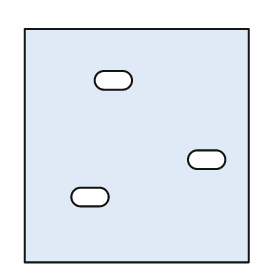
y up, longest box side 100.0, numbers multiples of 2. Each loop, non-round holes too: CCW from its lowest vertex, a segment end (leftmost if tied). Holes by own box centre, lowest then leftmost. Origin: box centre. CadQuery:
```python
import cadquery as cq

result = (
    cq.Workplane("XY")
    .moveTo(-48.0, -50.0)
    .lineTo(48.0, -50.0)
    .lineTo(48.0, 50.0)
    .lineTo(-48.0, 50.0)
    .close()
    .moveTo(-24.0, -26.0)
    .lineTo(-16.0, -26.0)
    .threePointArc((-12.0, -22.0), (-16.0, -18.0))
    .lineTo(-24.0, -18.0)
    .threePointArc((-28.0, -22.0), (-24.0, -26.0))
    .close()
    .moveTo(26.0, -10.0)
    .lineTo(34.0, -10.0)
    .threePointArc((38.0, -6.0), (34.0, -2.0))
    .lineTo(26.0, -2.0)
    .threePointArc((22.0, -6.0), (26.0, -10.0))
    .close()
    .moveTo(-14.0, 24.0)
    .lineTo(-6.0, 24.0)
    .threePointArc((-2.0, 28.0), (-6.0, 32.0))
    .lineTo(-14.0, 32.0)
    .threePointArc((-18.0, 28.0), (-14.0, 24.0))
    .close()
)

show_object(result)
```